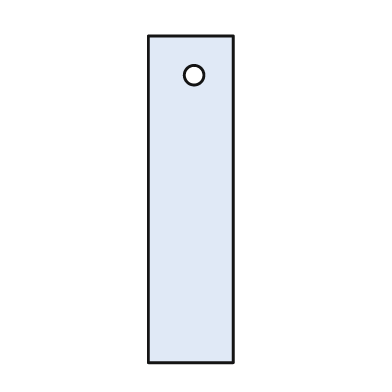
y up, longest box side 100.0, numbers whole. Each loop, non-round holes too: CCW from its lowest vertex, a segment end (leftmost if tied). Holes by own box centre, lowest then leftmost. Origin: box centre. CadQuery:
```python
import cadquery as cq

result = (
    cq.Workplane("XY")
    .moveTo(-13.0, -50.0)
    .lineTo(13.0, -50.0)
    .lineTo(13.0, 50.0)
    .lineTo(-13.0, 50.0)
    .close()
    .moveTo(1.0, 38.0)
    .circle(3.0)
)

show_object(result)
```